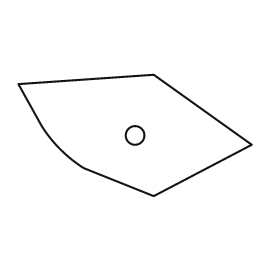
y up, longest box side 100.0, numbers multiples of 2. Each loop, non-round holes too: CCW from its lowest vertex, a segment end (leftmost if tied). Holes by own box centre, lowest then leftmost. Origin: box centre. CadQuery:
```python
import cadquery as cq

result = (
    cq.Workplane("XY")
    .moveTo(8.0, -26.0)
    .lineTo(50.0, -4.0)
    .lineTo(8.0, 26.0)
    .lineTo(-50.0, 22.0)
    .lineTo(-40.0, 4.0)
    .threePointArc((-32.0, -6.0), (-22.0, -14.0))
    .close()
    .moveTo(0.0, 0.0)
    .circle(4.0)
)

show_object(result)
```